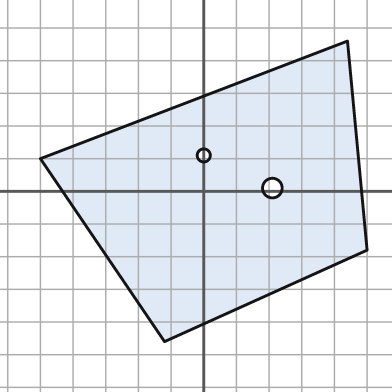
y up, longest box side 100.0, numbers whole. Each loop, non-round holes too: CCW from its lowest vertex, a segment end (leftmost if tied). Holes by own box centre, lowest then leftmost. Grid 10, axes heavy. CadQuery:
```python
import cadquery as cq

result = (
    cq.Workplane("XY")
    .moveTo(-12.0, -46.0)
    .lineTo(50.0, -18.0)
    .lineTo(44.0, 46.0)
    .lineTo(-50.0, 10.0)
    .close()
    .moveTo(21.0, 1.0)
    .circle(3.0)
    .moveTo(0.0, 11.0)
    .circle(2.0)
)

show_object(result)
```